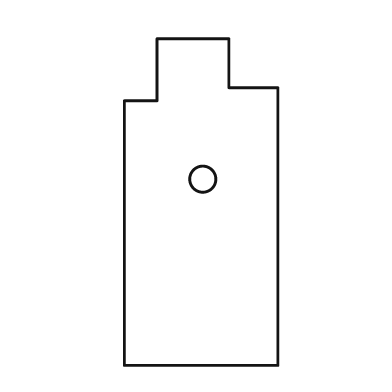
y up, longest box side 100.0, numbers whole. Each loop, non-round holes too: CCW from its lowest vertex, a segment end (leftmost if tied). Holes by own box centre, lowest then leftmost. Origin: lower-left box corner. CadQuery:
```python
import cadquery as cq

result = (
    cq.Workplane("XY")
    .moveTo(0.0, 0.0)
    .lineTo(47.0, 0.0)
    .lineTo(47.0, 85.0)
    .lineTo(32.0, 85.0)
    .lineTo(32.0, 100.0)
    .lineTo(10.0, 100.0)
    .lineTo(10.0, 81.0)
    .lineTo(0.0, 81.0)
    .close()
    .moveTo(24.0, 57.0)
    .circle(4.0)
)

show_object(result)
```